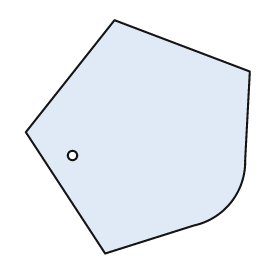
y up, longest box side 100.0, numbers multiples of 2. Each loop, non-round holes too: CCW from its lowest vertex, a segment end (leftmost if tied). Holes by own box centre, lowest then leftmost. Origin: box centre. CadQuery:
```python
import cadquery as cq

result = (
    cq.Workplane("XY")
    .moveTo(-14.0, -50.0)
    .lineTo(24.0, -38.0)
    .threePointArc((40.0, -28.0), (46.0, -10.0))
    .lineTo(48.0, 28.0)
    .lineTo(-10.0, 50.0)
    .lineTo(-48.0, 2.0)
    .close()
    .moveTo(-28.0, -8.0)
    .circle(2.0)
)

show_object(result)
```